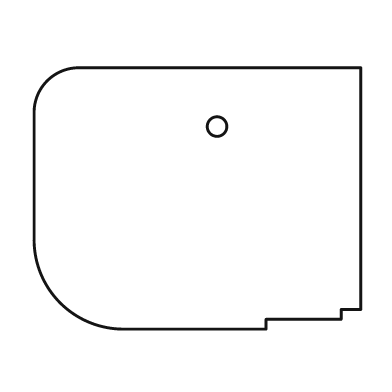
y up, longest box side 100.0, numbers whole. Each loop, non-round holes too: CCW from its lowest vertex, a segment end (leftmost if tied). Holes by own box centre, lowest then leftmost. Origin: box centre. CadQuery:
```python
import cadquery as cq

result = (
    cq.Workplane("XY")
    .moveTo(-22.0, -40.0)
    .lineTo(21.0, -40.0)
    .lineTo(21.0, -37.0)
    .lineTo(44.0, -37.0)
    .lineTo(44.0, -34.0)
    .lineTo(50.0, -34.0)
    .lineTo(50.0, 40.0)
    .lineTo(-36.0, 40.0)
    .threePointArc((-46.0, 36.0), (-50.0, 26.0))
    .lineTo(-50.0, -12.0)
    .threePointArc((-42.0, -32.0), (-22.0, -40.0))
    .close()
    .moveTo(6.0, 22.0)
    .circle(3.0)
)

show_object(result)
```